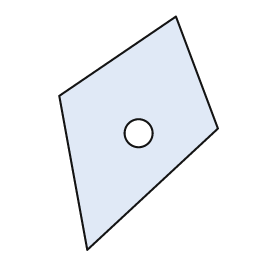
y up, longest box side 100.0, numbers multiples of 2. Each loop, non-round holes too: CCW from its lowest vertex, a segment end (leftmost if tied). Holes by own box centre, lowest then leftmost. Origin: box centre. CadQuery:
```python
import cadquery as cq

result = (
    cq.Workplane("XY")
    .moveTo(-22.0, -50.0)
    .lineTo(34.0, 2.0)
    .lineTo(16.0, 50.0)
    .lineTo(-34.0, 16.0)
    .close()
    .moveTo(0.0, 0.0)
    .circle(6.0)
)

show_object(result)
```